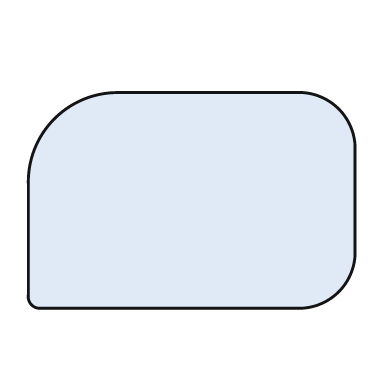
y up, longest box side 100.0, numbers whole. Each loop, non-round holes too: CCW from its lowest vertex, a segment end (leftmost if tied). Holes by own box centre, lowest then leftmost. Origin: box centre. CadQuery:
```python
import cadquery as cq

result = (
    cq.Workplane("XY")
    .moveTo(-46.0, -33.0)
    .lineTo(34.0, -33.0)
    .threePointArc((45.0, -28.0), (50.0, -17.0))
    .lineTo(50.0, 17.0)
    .threePointArc((45.0, 28.0), (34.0, 33.0))
    .lineTo(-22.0, 33.0)
    .threePointArc((-42.0, 25.0), (-50.0, 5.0))
    .lineTo(-50.0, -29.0)
    .threePointArc((-49.0, -32.0), (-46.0, -33.0))
    .close()
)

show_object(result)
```